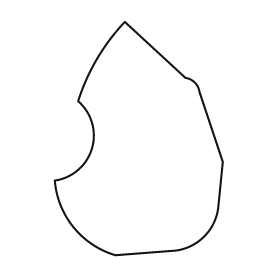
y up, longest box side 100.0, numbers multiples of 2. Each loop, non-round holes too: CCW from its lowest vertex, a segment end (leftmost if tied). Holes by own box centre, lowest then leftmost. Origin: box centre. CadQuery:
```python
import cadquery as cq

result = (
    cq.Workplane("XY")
    .moveTo(-10.0, -50.0)
    .lineTo(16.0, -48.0)
    .threePointArc((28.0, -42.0), (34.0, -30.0))
    .lineTo(36.0, -10.0)
    .lineTo(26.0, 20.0)
    .threePointArc((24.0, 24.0), (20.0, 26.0))
    .lineTo(-6.0, 50.0)
    .threePointArc((-18.0, 34.0), (-26.0, 16.0))
    .threePointArc((-20.0, -4.0), (-36.0, -18.0))
    .threePointArc((-28.0, -38.0), (-10.0, -50.0))
    .close()
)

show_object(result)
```